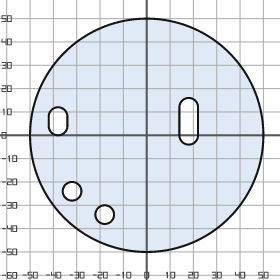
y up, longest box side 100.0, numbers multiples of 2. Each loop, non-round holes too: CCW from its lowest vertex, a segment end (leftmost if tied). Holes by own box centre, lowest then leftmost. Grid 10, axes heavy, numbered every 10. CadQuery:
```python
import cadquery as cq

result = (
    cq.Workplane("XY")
    .moveTo(0.0, 0.0)
    .circle(50.0)
    .moveTo(-18.0, -34.0)
    .circle(4.0)
    .moveTo(-32.0, -24.0)
    .circle(4.0)
    .moveTo(-42.0, 4.0)
    .threePointArc((-38.0, 0.0), (-34.0, 4.0))
    .lineTo(-34.0, 8.0)
    .threePointArc((-38.0, 12.0), (-42.0, 8.0))
    .close()
    .moveTo(14.0, 0.0)
    .threePointArc((18.0, -4.0), (22.0, 0.0))
    .lineTo(22.0, 12.0)
    .threePointArc((18.0, 16.0), (14.0, 12.0))
    .close()
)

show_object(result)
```